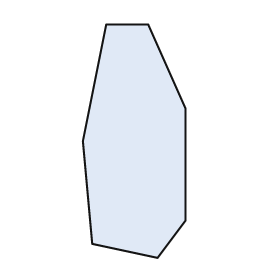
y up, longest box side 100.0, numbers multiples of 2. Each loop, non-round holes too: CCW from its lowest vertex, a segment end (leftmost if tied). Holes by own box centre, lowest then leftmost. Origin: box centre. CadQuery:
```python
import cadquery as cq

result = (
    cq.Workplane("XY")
    .moveTo(10.0, -50.0)
    .lineTo(22.0, -34.0)
    .lineTo(22.0, 14.0)
    .lineTo(6.0, 50.0)
    .lineTo(-12.0, 50.0)
    .lineTo(-22.0, 0.0)
    .lineTo(-18.0, -44.0)
    .close()
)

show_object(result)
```